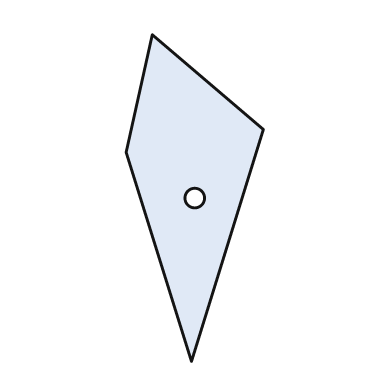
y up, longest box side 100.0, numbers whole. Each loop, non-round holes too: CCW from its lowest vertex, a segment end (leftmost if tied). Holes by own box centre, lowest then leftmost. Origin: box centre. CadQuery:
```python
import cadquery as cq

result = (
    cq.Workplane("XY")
    .moveTo(-1.0, -50.0)
    .lineTo(21.0, 21.0)
    .lineTo(-13.0, 50.0)
    .lineTo(-21.0, 14.0)
    .close()
    .moveTo(0.0, 0.0)
    .circle(3.0)
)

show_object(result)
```